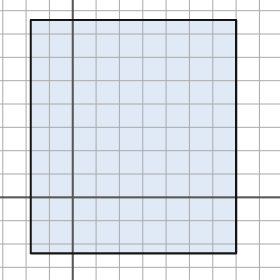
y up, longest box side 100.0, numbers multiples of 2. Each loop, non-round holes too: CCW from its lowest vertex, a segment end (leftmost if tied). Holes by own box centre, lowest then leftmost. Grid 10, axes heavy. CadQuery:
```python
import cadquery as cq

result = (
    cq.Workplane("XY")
    .moveTo(-18.0, -24.0)
    .lineTo(70.0, -24.0)
    .lineTo(70.0, 76.0)
    .lineTo(-18.0, 76.0)
    .close()
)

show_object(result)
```